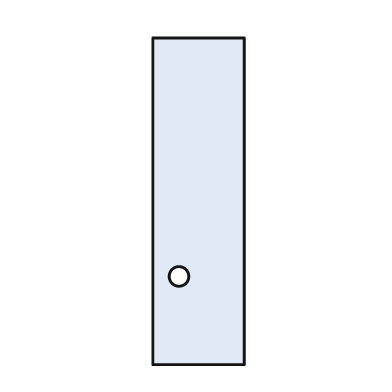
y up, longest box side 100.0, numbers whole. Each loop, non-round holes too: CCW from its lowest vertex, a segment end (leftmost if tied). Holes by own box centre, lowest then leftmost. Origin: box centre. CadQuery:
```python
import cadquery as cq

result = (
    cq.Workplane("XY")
    .moveTo(-14.0, -50.0)
    .lineTo(14.0, -50.0)
    .lineTo(14.0, 50.0)
    .lineTo(-14.0, 50.0)
    .close()
    .moveTo(-6.0, -23.0)
    .circle(3.0)
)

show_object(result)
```